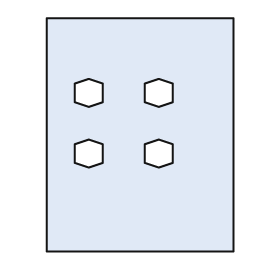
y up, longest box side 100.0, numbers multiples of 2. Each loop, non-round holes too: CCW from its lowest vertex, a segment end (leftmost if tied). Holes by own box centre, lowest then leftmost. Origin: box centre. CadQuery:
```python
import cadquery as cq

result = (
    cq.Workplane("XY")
    .moveTo(-40.0, -50.0)
    .lineTo(40.0, -50.0)
    .lineTo(40.0, 50.0)
    .lineTo(-40.0, 50.0)
    .close()
    .moveTo(-22.0, -14.0)
    .lineTo(-16.0, -12.0)
    .lineTo(-16.0, -4.0)
    .lineTo(-22.0, -2.0)
    .lineTo(-28.0, -4.0)
    .lineTo(-28.0, -12.0)
    .close()
    .moveTo(8.0, -14.0)
    .lineTo(14.0, -12.0)
    .lineTo(14.0, -4.0)
    .lineTo(8.0, -2.0)
    .lineTo(2.0, -4.0)
    .lineTo(2.0, -12.0)
    .close()
    .moveTo(-22.0, 12.0)
    .lineTo(-16.0, 14.0)
    .lineTo(-16.0, 22.0)
    .lineTo(-22.0, 24.0)
    .lineTo(-28.0, 22.0)
    .lineTo(-28.0, 14.0)
    .close()
    .moveTo(8.0, 12.0)
    .lineTo(14.0, 14.0)
    .lineTo(14.0, 22.0)
    .lineTo(8.0, 24.0)
    .lineTo(2.0, 22.0)
    .lineTo(2.0, 14.0)
    .close()
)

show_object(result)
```